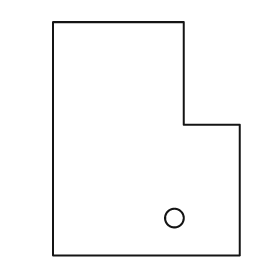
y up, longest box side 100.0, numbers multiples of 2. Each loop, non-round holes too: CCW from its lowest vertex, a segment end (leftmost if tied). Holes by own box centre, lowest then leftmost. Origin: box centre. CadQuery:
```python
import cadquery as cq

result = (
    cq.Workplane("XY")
    .moveTo(-40.0, -50.0)
    .lineTo(40.0, -50.0)
    .lineTo(40.0, 6.0)
    .lineTo(16.0, 6.0)
    .lineTo(16.0, 50.0)
    .lineTo(-40.0, 50.0)
    .close()
    .moveTo(12.0, -34.0)
    .circle(4.0)
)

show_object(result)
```